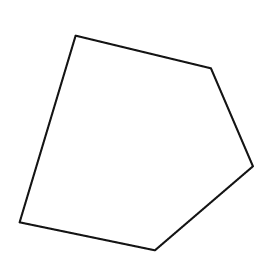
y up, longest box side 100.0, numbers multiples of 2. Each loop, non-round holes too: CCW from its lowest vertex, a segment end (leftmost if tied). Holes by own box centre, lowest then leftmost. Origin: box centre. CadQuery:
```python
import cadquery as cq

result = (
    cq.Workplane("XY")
    .moveTo(8.0, -46.0)
    .lineTo(50.0, -10.0)
    .lineTo(32.0, 32.0)
    .lineTo(-26.0, 46.0)
    .lineTo(-50.0, -34.0)
    .close()
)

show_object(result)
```